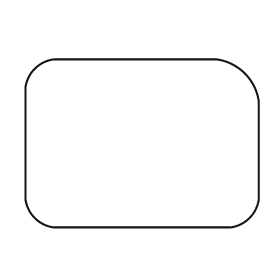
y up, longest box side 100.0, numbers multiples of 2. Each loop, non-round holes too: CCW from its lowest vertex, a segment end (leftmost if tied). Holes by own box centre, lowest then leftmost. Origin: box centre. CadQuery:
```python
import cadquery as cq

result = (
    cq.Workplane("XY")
    .moveTo(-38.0, -36.0)
    .lineTo(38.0, -36.0)
    .threePointArc((46.0, -32.0), (50.0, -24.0))
    .lineTo(50.0, 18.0)
    .threePointArc((44.0, 30.0), (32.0, 36.0))
    .lineTo(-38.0, 36.0)
    .threePointArc((-46.0, 32.0), (-50.0, 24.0))
    .lineTo(-50.0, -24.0)
    .threePointArc((-46.0, -32.0), (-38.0, -36.0))
    .close()
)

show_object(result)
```